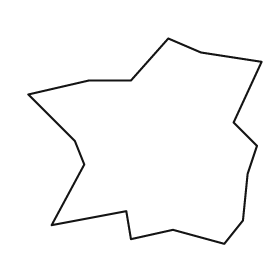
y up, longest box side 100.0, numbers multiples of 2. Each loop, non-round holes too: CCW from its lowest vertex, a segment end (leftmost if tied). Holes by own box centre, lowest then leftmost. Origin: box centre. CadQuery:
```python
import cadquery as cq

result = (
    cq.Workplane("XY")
    .moveTo(34.0, -44.0)
    .lineTo(42.0, -34.0)
    .lineTo(44.0, -14.0)
    .lineTo(48.0, -2.0)
    .lineTo(38.0, 8.0)
    .lineTo(50.0, 34.0)
    .lineTo(24.0, 38.0)
    .lineTo(10.0, 44.0)
    .lineTo(-6.0, 26.0)
    .lineTo(-24.0, 26.0)
    .lineTo(-50.0, 20.0)
    .lineTo(-30.0, 0.0)
    .lineTo(-26.0, -10.0)
    .lineTo(-40.0, -36.0)
    .lineTo(-8.0, -30.0)
    .lineTo(-6.0, -42.0)
    .lineTo(12.0, -38.0)
    .close()
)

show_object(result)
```